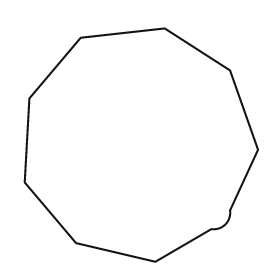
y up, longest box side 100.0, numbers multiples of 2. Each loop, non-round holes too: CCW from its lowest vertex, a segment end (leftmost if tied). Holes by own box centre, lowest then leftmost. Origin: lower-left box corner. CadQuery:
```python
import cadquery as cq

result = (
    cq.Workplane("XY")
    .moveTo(56.0, 0.0)
    .lineTo(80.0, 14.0)
    .threePointArc((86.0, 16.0), (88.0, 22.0))
    .lineTo(100.0, 48.0)
    .lineTo(88.0, 82.0)
    .lineTo(60.0, 100.0)
    .lineTo(24.0, 96.0)
    .lineTo(2.0, 70.0)
    .lineTo(0.0, 34.0)
    .lineTo(22.0, 8.0)
    .close()
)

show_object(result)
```